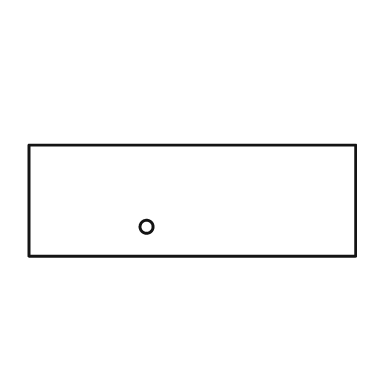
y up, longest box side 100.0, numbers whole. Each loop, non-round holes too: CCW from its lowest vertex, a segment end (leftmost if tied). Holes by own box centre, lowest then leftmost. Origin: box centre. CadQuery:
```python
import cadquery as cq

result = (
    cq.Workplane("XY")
    .moveTo(-50.0, -17.0)
    .lineTo(50.0, -17.0)
    .lineTo(50.0, 17.0)
    .lineTo(-50.0, 17.0)
    .close()
    .moveTo(-14.0, -8.0)
    .circle(2.0)
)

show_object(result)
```